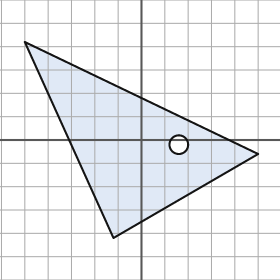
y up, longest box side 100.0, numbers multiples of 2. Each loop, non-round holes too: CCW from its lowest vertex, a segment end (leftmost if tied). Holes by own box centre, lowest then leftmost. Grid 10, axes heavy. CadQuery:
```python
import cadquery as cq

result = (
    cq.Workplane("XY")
    .moveTo(-12.0, -42.0)
    .lineTo(50.0, -6.0)
    .lineTo(-50.0, 42.0)
    .close()
    .moveTo(16.0, -2.0)
    .circle(4.0)
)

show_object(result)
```